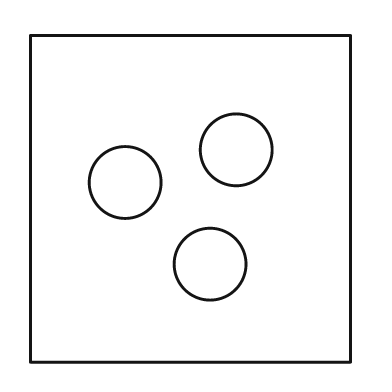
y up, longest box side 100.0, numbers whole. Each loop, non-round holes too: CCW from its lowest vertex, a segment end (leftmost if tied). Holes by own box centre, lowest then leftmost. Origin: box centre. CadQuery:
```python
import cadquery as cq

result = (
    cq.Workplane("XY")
    .moveTo(-49.0, -50.0)
    .lineTo(49.0, -50.0)
    .lineTo(49.0, 50.0)
    .lineTo(-49.0, 50.0)
    .close()
    .moveTo(6.0, -20.0)
    .circle(11.0)
    .moveTo(-20.0, 5.0)
    .circle(11.0)
    .moveTo(14.0, 15.0)
    .circle(11.0)
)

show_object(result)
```